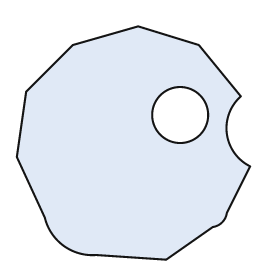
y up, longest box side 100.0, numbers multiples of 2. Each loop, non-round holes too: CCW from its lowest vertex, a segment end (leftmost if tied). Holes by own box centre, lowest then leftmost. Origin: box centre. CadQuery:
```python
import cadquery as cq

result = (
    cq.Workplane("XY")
    .moveTo(14.0, -50.0)
    .lineTo(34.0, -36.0)
    .threePointArc((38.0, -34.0), (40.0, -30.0))
    .lineTo(50.0, -10.0)
    .threePointArc((40.0, 4.0), (46.0, 20.0))
    .lineTo(28.0, 42.0)
    .lineTo(2.0, 50.0)
    .lineTo(-26.0, 42.0)
    .lineTo(-46.0, 22.0)
    .lineTo(-50.0, -6.0)
    .lineTo(-38.0, -32.0)
    .threePointArc((-30.0, -44.0), (-16.0, -48.0))
    .close()
    .moveTo(20.0, 12.0)
    .circle(12.0)
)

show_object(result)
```